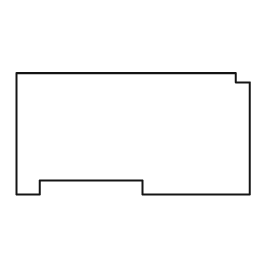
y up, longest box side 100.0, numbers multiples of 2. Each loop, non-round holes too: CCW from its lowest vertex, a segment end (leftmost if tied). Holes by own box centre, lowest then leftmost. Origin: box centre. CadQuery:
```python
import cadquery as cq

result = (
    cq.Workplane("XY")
    .moveTo(-50.0, -26.0)
    .lineTo(-40.0, -26.0)
    .lineTo(-40.0, -20.0)
    .lineTo(4.0, -20.0)
    .lineTo(4.0, -26.0)
    .lineTo(50.0, -26.0)
    .lineTo(50.0, 22.0)
    .lineTo(44.0, 22.0)
    .lineTo(44.0, 26.0)
    .lineTo(-50.0, 26.0)
    .close()
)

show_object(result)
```